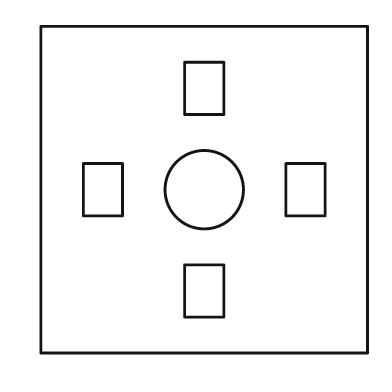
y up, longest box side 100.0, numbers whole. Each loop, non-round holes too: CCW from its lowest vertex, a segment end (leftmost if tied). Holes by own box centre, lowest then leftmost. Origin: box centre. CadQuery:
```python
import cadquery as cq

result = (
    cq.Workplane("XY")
    .moveTo(-50.0, -50.0)
    .lineTo(50.0, -50.0)
    .lineTo(50.0, 50.0)
    .lineTo(-50.0, 50.0)
    .close()
    .moveTo(-6.0, -39.0)
    .lineTo(6.0, -39.0)
    .lineTo(6.0, -23.0)
    .lineTo(-6.0, -23.0)
    .close()
    .moveTo(-37.0, -8.0)
    .lineTo(-25.0, -8.0)
    .lineTo(-25.0, 8.0)
    .lineTo(-37.0, 8.0)
    .close()
    .moveTo(0.0, 0.0)
    .circle(12.0)
    .moveTo(25.0, -8.0)
    .lineTo(37.0, -8.0)
    .lineTo(37.0, 8.0)
    .lineTo(25.0, 8.0)
    .close()
    .moveTo(-6.0, 23.0)
    .lineTo(6.0, 23.0)
    .lineTo(6.0, 39.0)
    .lineTo(-6.0, 39.0)
    .close()
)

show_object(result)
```